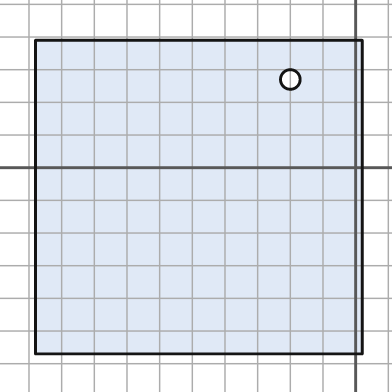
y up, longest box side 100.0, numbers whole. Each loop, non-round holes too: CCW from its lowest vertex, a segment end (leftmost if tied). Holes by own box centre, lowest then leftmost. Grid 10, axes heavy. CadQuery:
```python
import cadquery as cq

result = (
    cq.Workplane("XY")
    .moveTo(-98.0, -57.0)
    .lineTo(2.0, -57.0)
    .lineTo(2.0, 39.0)
    .lineTo(-98.0, 39.0)
    .close()
    .moveTo(-20.0, 27.0)
    .circle(3.0)
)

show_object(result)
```